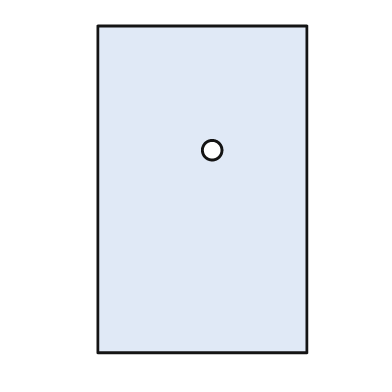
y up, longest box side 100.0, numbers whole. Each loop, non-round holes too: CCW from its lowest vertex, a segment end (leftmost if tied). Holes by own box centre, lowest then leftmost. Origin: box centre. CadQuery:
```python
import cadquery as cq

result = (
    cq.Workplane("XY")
    .moveTo(-32.0, -50.0)
    .lineTo(32.0, -50.0)
    .lineTo(32.0, 50.0)
    .lineTo(-32.0, 50.0)
    .close()
    .moveTo(3.0, 12.0)
    .circle(3.0)
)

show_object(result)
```